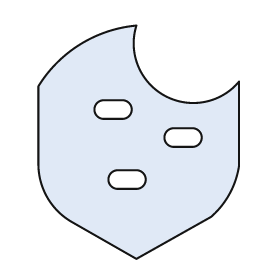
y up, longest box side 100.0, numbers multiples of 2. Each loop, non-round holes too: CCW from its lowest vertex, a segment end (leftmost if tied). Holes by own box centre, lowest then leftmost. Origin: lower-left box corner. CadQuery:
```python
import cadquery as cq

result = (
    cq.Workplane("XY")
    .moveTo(42.0, 0.0)
    .lineTo(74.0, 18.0)
    .threePointArc((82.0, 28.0), (86.0, 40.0))
    .lineTo(86.0, 76.0)
    .threePointArc((54.0, 70.0), (42.0, 100.0))
    .threePointArc((18.0, 92.0), (0.0, 74.0))
    .lineTo(0.0, 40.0)
    .threePointArc((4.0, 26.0), (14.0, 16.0))
    .close()
    .moveTo(34.0, 30.0)
    .lineTo(42.0, 30.0)
    .threePointArc((46.0, 34.0), (42.0, 38.0))
    .lineTo(34.0, 38.0)
    .threePointArc((30.0, 34.0), (34.0, 30.0))
    .close()
    .moveTo(58.0, 48.0)
    .lineTo(66.0, 48.0)
    .threePointArc((70.0, 52.0), (66.0, 56.0))
    .lineTo(58.0, 56.0)
    .threePointArc((54.0, 52.0), (58.0, 48.0))
    .close()
    .moveTo(28.0, 60.0)
    .lineTo(36.0, 60.0)
    .threePointArc((40.0, 64.0), (36.0, 68.0))
    .lineTo(28.0, 68.0)
    .threePointArc((24.0, 64.0), (28.0, 60.0))
    .close()
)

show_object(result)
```